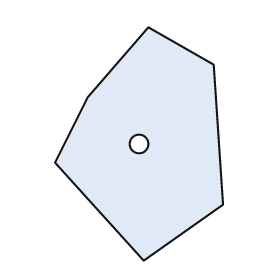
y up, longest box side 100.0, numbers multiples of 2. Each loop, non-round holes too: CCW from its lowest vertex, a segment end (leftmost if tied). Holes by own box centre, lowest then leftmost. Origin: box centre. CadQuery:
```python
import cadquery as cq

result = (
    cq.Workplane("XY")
    .moveTo(2.0, -50.0)
    .lineTo(36.0, -26.0)
    .lineTo(32.0, 34.0)
    .lineTo(4.0, 50.0)
    .lineTo(-22.0, 20.0)
    .lineTo(-36.0, -8.0)
    .close()
    .moveTo(0.0, 0.0)
    .circle(4.0)
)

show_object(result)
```